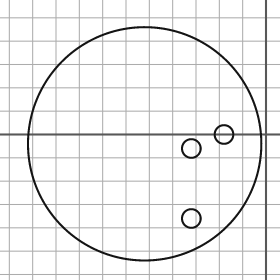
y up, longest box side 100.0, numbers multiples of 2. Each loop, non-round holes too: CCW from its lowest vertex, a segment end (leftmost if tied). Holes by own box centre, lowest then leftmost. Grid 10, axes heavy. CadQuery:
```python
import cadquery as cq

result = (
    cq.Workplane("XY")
    .moveTo(-52.0, -4.0)
    .circle(50.0)
    .moveTo(-32.0, -36.0)
    .circle(4.0)
    .moveTo(-32.0, -6.0)
    .circle(4.0)
    .moveTo(-18.0, 0.0)
    .circle(4.0)
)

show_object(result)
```